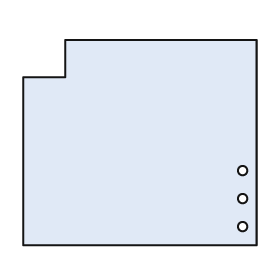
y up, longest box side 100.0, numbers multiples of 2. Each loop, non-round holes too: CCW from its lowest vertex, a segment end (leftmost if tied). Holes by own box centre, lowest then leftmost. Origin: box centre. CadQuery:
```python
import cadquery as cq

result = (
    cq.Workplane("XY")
    .moveTo(-50.0, -44.0)
    .lineTo(50.0, -44.0)
    .lineTo(50.0, 44.0)
    .lineTo(-32.0, 44.0)
    .lineTo(-32.0, 28.0)
    .lineTo(-50.0, 28.0)
    .close()
    .moveTo(44.0, -36.0)
    .circle(2.0)
    .moveTo(44.0, -24.0)
    .circle(2.0)
    .moveTo(44.0, -12.0)
    .circle(2.0)
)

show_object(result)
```